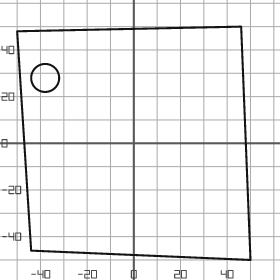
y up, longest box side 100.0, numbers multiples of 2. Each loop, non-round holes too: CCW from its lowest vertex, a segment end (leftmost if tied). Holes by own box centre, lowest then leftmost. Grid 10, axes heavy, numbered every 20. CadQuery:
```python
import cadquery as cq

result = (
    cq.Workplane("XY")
    .moveTo(50.0, -50.0)
    .lineTo(46.0, 50.0)
    .lineTo(-50.0, 48.0)
    .lineTo(-44.0, -46.0)
    .close()
    .moveTo(-38.0, 28.0)
    .circle(6.0)
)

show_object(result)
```